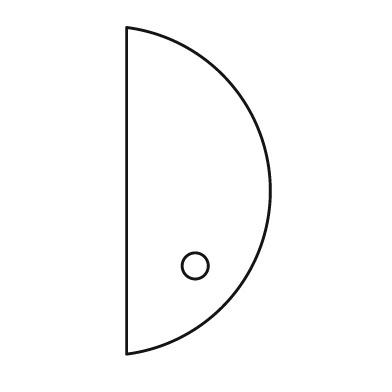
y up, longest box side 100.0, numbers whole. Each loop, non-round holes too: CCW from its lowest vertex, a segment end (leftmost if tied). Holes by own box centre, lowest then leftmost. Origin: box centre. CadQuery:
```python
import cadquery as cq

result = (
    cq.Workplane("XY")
    .moveTo(-22.0, -50.0)
    .threePointArc((22.0, 0.0), (-22.0, 50.0))
    .close()
    .moveTo(-1.0, -23.0)
    .circle(4.0)
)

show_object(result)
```